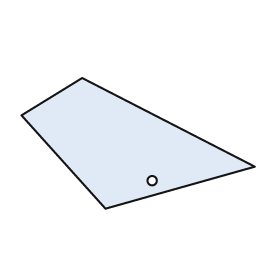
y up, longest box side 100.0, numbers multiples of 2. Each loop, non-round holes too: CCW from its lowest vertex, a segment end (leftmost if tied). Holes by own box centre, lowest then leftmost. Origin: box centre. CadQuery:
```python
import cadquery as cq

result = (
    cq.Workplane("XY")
    .moveTo(-14.0, -28.0)
    .lineTo(50.0, -10.0)
    .lineTo(-24.0, 28.0)
    .lineTo(-50.0, 12.0)
    .close()
    .moveTo(6.0, -16.0)
    .circle(2.0)
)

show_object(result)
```